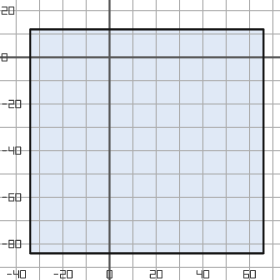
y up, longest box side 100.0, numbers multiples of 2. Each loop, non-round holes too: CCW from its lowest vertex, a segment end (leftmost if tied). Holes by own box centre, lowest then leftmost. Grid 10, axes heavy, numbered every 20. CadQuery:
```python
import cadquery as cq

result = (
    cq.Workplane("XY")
    .moveTo(-34.0, -84.0)
    .lineTo(66.0, -84.0)
    .lineTo(66.0, 12.0)
    .lineTo(-34.0, 12.0)
    .close()
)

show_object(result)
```